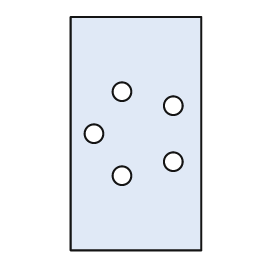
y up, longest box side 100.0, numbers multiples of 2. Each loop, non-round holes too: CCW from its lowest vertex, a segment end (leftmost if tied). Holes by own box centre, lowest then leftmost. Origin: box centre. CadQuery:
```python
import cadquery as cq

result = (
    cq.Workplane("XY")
    .moveTo(-28.0, -50.0)
    .lineTo(28.0, -50.0)
    .lineTo(28.0, 50.0)
    .lineTo(-28.0, 50.0)
    .close()
    .moveTo(-6.0, -18.0)
    .circle(4.0)
    .moveTo(16.0, -12.0)
    .circle(4.0)
    .moveTo(-18.0, 0.0)
    .circle(4.0)
    .moveTo(16.0, 12.0)
    .circle(4.0)
    .moveTo(-6.0, 18.0)
    .circle(4.0)
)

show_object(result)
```